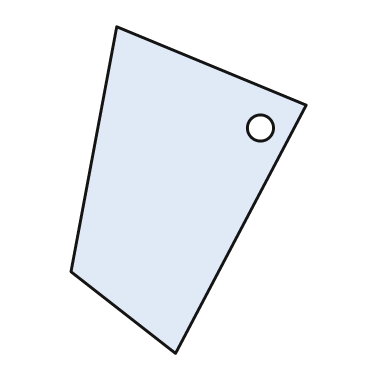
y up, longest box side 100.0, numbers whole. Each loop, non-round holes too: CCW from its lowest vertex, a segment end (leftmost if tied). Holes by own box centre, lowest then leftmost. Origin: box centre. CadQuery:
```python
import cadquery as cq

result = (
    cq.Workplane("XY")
    .moveTo(-4.0, -50.0)
    .lineTo(36.0, 26.0)
    .lineTo(-22.0, 50.0)
    .lineTo(-36.0, -25.0)
    .close()
    .moveTo(22.0, 19.0)
    .circle(4.0)
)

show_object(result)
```